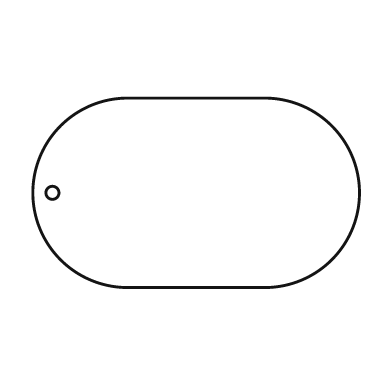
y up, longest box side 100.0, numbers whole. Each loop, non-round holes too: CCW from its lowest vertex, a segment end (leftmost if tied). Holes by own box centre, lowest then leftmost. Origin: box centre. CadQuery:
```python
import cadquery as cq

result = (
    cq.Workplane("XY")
    .moveTo(-21.0, -29.0)
    .lineTo(21.0, -29.0)
    .threePointArc((50.0, 0.0), (21.0, 29.0))
    .lineTo(-21.0, 29.0)
    .threePointArc((-50.0, 0.0), (-21.0, -29.0))
    .close()
    .moveTo(-44.0, 0.0)
    .circle(2.0)
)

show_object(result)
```